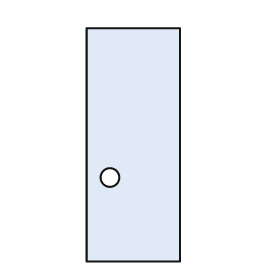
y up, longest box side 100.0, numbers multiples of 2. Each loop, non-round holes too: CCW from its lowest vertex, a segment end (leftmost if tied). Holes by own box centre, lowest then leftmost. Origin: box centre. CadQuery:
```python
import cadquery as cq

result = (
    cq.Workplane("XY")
    .moveTo(-20.0, -50.0)
    .lineTo(20.0, -50.0)
    .lineTo(20.0, 50.0)
    .lineTo(-20.0, 50.0)
    .close()
    .moveTo(-10.0, -14.0)
    .circle(4.0)
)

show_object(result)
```